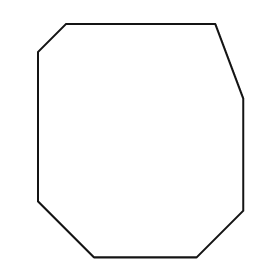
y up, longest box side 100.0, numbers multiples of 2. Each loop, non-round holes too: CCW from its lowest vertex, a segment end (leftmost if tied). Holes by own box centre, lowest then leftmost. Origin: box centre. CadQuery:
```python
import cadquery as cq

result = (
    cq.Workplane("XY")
    .moveTo(-20.0, -50.0)
    .lineTo(24.0, -50.0)
    .lineTo(44.0, -30.0)
    .lineTo(44.0, 18.0)
    .lineTo(32.0, 50.0)
    .lineTo(-32.0, 50.0)
    .lineTo(-44.0, 38.0)
    .lineTo(-44.0, -26.0)
    .close()
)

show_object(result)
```